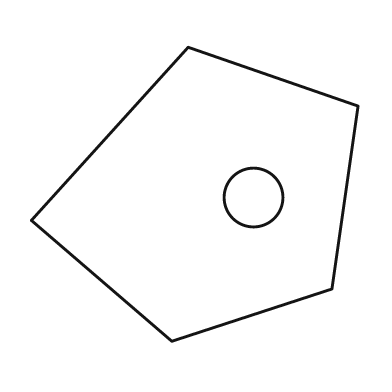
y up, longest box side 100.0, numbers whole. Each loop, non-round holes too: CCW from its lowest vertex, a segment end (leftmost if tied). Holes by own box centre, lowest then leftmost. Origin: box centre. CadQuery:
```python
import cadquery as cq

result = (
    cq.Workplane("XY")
    .moveTo(-7.0, -45.0)
    .lineTo(42.0, -29.0)
    .lineTo(50.0, 27.0)
    .lineTo(-2.0, 45.0)
    .lineTo(-50.0, -8.0)
    .close()
    .moveTo(18.0, -1.0)
    .circle(9.0)
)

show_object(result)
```